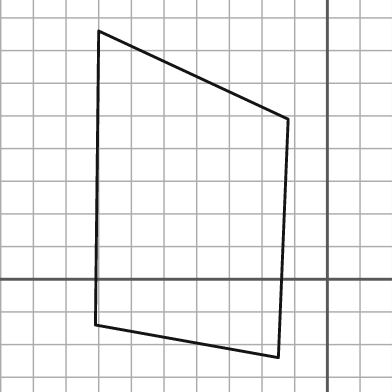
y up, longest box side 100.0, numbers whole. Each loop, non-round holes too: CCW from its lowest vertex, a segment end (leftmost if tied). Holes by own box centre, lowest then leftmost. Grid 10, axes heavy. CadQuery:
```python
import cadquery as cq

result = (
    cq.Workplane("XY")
    .moveTo(-15.0, -24.0)
    .lineTo(-12.0, 49.0)
    .lineTo(-70.0, 76.0)
    .lineTo(-71.0, -14.0)
    .close()
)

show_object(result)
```